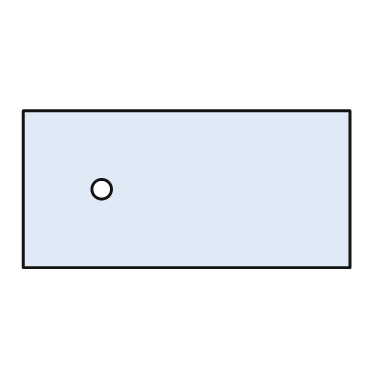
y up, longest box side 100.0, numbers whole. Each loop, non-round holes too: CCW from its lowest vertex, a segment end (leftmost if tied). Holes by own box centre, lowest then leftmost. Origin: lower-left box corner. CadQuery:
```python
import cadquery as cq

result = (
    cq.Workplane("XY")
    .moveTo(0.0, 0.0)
    .lineTo(100.0, 0.0)
    .lineTo(100.0, 48.0)
    .lineTo(0.0, 48.0)
    .close()
    .moveTo(24.0, 24.0)
    .circle(3.0)
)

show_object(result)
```